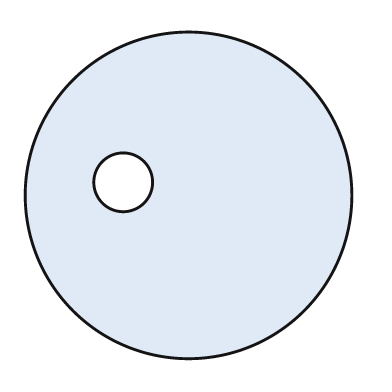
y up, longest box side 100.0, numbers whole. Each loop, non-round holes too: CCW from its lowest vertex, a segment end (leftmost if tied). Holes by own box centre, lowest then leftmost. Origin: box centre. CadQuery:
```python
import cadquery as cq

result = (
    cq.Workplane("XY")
    .moveTo(0.0, 0.0)
    .circle(50.0)
    .moveTo(-20.0, 4.0)
    .circle(9.0)
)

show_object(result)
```